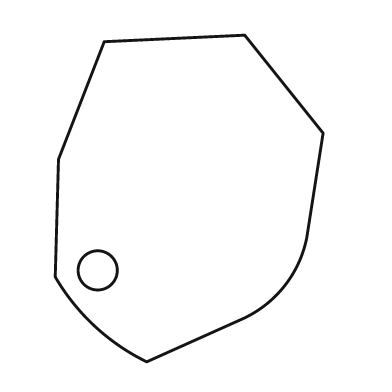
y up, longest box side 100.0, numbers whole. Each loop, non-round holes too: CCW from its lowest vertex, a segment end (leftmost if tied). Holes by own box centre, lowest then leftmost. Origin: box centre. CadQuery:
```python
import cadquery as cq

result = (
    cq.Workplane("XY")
    .moveTo(-13.0, -50.0)
    .lineTo(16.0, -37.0)
    .threePointArc((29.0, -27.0), (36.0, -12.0))
    .lineTo(41.0, 20.0)
    .lineTo(17.0, 50.0)
    .lineTo(-26.0, 48.0)
    .lineTo(-40.0, 12.0)
    .lineTo(-41.0, -24.0)
    .threePointArc((-29.0, -39.0), (-13.0, -50.0))
    .close()
    .moveTo(-28.0, -22.0)
    .circle(6.0)
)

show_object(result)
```